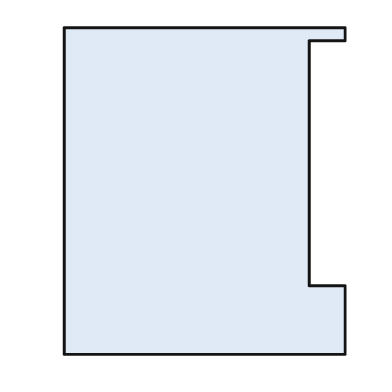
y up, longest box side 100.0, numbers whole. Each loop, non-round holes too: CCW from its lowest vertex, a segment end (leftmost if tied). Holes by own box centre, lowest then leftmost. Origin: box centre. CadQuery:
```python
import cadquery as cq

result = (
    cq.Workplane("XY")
    .moveTo(-43.0, -50.0)
    .lineTo(43.0, -50.0)
    .lineTo(43.0, -29.0)
    .lineTo(32.0, -29.0)
    .lineTo(32.0, 46.0)
    .lineTo(43.0, 46.0)
    .lineTo(43.0, 50.0)
    .lineTo(-43.0, 50.0)
    .close()
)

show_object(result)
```